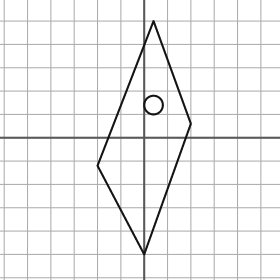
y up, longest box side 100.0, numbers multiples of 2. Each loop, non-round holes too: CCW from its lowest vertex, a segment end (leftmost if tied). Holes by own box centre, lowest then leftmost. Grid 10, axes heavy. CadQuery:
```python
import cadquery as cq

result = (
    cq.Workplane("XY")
    .moveTo(0.0, -50.0)
    .lineTo(20.0, 6.0)
    .lineTo(4.0, 50.0)
    .lineTo(-20.0, -12.0)
    .close()
    .moveTo(4.0, 14.0)
    .circle(4.0)
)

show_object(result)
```